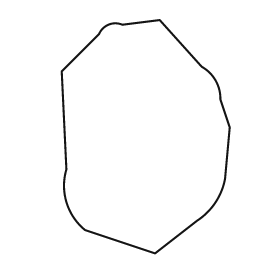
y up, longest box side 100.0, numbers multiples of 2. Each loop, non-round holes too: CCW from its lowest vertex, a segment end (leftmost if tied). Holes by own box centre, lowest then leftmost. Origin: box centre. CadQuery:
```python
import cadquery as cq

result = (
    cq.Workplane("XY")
    .moveTo(4.0, -50.0)
    .lineTo(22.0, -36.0)
    .threePointArc((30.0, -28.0), (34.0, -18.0))
    .lineTo(36.0, 4.0)
    .lineTo(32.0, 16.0)
    .threePointArc((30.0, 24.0), (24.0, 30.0))
    .lineTo(6.0, 50.0)
    .lineTo(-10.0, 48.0)
    .threePointArc((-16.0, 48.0), (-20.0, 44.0))
    .lineTo(-36.0, 28.0)
    .lineTo(-34.0, -14.0)
    .threePointArc((-34.0, -28.0), (-26.0, -40.0))
    .close()
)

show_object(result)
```